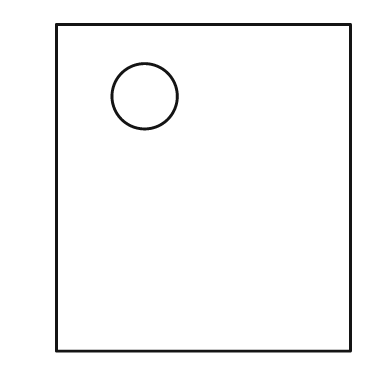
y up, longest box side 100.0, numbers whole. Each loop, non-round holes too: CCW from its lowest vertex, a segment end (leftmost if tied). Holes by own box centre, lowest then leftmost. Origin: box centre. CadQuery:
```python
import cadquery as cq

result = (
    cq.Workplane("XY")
    .moveTo(-45.0, -50.0)
    .lineTo(45.0, -50.0)
    .lineTo(45.0, 50.0)
    .lineTo(-45.0, 50.0)
    .close()
    .moveTo(-18.0, 28.0)
    .circle(10.0)
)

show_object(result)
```